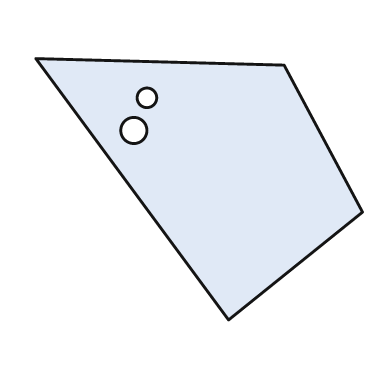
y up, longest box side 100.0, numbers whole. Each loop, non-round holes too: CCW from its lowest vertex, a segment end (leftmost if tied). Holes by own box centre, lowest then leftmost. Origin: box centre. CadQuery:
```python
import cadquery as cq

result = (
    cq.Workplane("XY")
    .moveTo(9.0, -40.0)
    .lineTo(50.0, -7.0)
    .lineTo(26.0, 38.0)
    .lineTo(-50.0, 40.0)
    .close()
    .moveTo(-20.0, 18.0)
    .circle(4.0)
    .moveTo(-16.0, 28.0)
    .circle(3.0)
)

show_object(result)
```